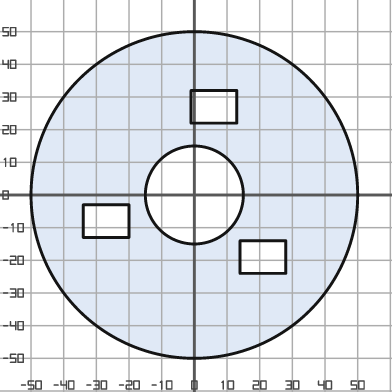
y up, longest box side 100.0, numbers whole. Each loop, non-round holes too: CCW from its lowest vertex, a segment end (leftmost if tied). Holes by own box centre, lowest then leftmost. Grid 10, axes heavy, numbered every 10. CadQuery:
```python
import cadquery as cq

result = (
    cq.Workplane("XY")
    .moveTo(0.0, 0.0)
    .circle(50.0)
    .moveTo(14.0, -24.0)
    .lineTo(28.0, -24.0)
    .lineTo(28.0, -14.0)
    .lineTo(14.0, -14.0)
    .close()
    .moveTo(-34.0, -13.0)
    .lineTo(-20.0, -13.0)
    .lineTo(-20.0, -3.0)
    .lineTo(-34.0, -3.0)
    .close()
    .moveTo(0.0, 0.0)
    .circle(15.0)
    .moveTo(-1.0, 22.0)
    .lineTo(13.0, 22.0)
    .lineTo(13.0, 32.0)
    .lineTo(-1.0, 32.0)
    .close()
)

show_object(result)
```